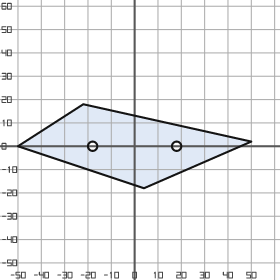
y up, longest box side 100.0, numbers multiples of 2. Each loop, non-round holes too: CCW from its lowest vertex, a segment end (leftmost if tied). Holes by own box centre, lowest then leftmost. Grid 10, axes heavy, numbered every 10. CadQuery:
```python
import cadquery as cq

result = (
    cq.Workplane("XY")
    .moveTo(4.0, -18.0)
    .lineTo(50.0, 2.0)
    .lineTo(-22.0, 18.0)
    .lineTo(-50.0, 0.0)
    .close()
    .moveTo(-18.0, 0.0)
    .circle(2.0)
    .moveTo(18.0, 0.0)
    .circle(2.0)
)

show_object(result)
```